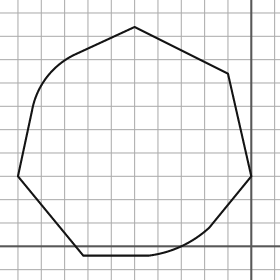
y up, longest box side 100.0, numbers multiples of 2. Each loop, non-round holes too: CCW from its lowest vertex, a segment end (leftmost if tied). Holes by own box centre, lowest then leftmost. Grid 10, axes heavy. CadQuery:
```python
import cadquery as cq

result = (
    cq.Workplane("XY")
    .moveTo(-72.0, -4.0)
    .lineTo(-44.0, -4.0)
    .threePointArc((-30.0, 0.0), (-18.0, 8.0))
    .lineTo(0.0, 30.0)
    .lineTo(-10.0, 74.0)
    .lineTo(-50.0, 94.0)
    .lineTo(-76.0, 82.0)
    .threePointArc((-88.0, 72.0), (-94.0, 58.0))
    .lineTo(-100.0, 30.0)
    .close()
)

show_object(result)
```